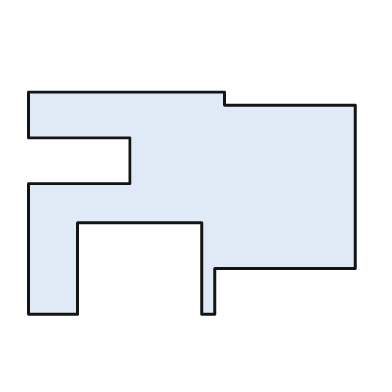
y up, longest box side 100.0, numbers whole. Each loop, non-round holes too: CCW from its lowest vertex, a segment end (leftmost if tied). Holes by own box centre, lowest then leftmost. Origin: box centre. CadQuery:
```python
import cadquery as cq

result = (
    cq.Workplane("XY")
    .moveTo(-50.0, -34.0)
    .lineTo(-35.0, -34.0)
    .lineTo(-35.0, -6.0)
    .lineTo(3.0, -6.0)
    .lineTo(3.0, -34.0)
    .lineTo(7.0, -34.0)
    .lineTo(7.0, -20.0)
    .lineTo(50.0, -20.0)
    .lineTo(50.0, 30.0)
    .lineTo(10.0, 30.0)
    .lineTo(10.0, 34.0)
    .lineTo(-50.0, 34.0)
    .lineTo(-50.0, 20.0)
    .lineTo(-19.0, 20.0)
    .lineTo(-19.0, 6.0)
    .lineTo(-50.0, 6.0)
    .close()
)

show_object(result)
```